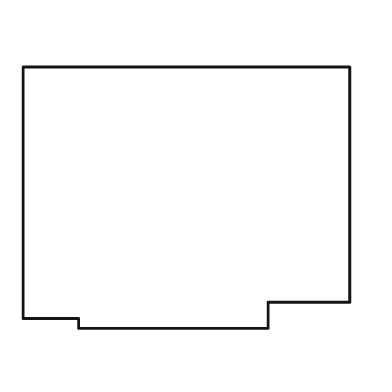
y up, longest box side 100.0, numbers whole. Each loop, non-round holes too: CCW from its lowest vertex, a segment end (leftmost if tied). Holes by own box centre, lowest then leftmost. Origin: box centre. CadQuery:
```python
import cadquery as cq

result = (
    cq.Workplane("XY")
    .moveTo(-33.0, -40.0)
    .lineTo(25.0, -40.0)
    .lineTo(25.0, -32.0)
    .lineTo(50.0, -32.0)
    .lineTo(50.0, 40.0)
    .lineTo(-50.0, 40.0)
    .lineTo(-50.0, -37.0)
    .lineTo(-33.0, -37.0)
    .close()
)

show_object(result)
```